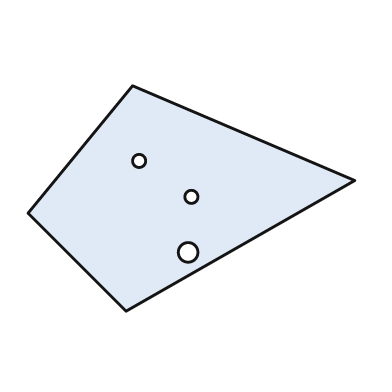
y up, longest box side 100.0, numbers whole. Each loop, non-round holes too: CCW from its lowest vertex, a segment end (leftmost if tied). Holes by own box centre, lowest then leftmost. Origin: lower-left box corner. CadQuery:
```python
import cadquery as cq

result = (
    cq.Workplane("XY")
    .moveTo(30.0, 0.0)
    .lineTo(100.0, 40.0)
    .lineTo(32.0, 69.0)
    .lineTo(0.0, 30.0)
    .close()
    .moveTo(49.0, 18.0)
    .circle(3.0)
    .moveTo(50.0, 35.0)
    .circle(2.0)
    .moveTo(34.0, 46.0)
    .circle(2.0)
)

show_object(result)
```